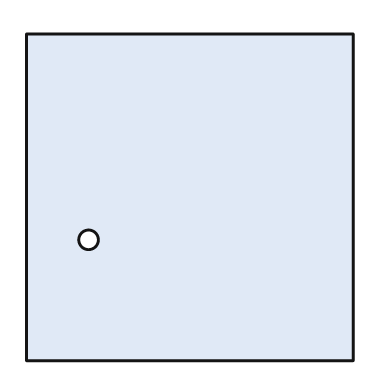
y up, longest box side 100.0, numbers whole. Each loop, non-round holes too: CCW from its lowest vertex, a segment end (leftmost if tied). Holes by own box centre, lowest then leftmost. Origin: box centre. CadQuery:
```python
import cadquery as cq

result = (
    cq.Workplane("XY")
    .moveTo(-50.0, -50.0)
    .lineTo(50.0, -50.0)
    .lineTo(50.0, 50.0)
    .lineTo(-50.0, 50.0)
    .close()
    .moveTo(-31.0, -13.0)
    .circle(3.0)
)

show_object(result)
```